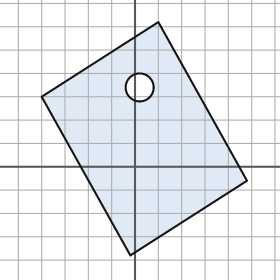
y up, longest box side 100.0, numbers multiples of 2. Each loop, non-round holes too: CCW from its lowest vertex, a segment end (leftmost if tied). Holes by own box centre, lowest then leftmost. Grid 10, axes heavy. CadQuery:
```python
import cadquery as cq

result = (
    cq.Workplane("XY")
    .moveTo(-2.0, -38.0)
    .lineTo(48.0, -6.0)
    .lineTo(10.0, 62.0)
    .lineTo(-40.0, 30.0)
    .close()
    .moveTo(2.0, 34.0)
    .circle(6.0)
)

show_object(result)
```